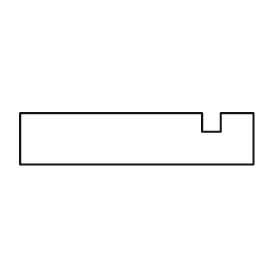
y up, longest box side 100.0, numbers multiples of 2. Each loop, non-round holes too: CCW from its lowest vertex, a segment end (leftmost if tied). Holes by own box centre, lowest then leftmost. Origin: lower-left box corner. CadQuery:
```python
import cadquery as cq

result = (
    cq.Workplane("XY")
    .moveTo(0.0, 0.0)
    .lineTo(100.0, 0.0)
    .lineTo(100.0, 22.0)
    .lineTo(86.0, 22.0)
    .lineTo(86.0, 14.0)
    .lineTo(78.0, 14.0)
    .lineTo(78.0, 22.0)
    .lineTo(0.0, 22.0)
    .close()
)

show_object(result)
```